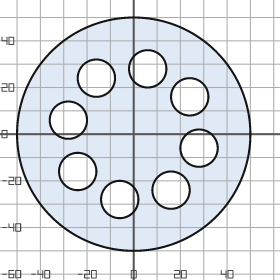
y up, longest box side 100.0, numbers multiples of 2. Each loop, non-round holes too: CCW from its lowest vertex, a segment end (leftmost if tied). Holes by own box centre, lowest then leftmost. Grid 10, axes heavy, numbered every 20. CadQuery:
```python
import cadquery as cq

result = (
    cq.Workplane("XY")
    .moveTo(0.0, 0.0)
    .circle(50.0)
    .moveTo(-6.0, -28.0)
    .circle(8.0)
    .moveTo(16.0, -24.0)
    .circle(8.0)
    .moveTo(-24.0, -16.0)
    .circle(8.0)
    .moveTo(28.0, -6.0)
    .circle(8.0)
    .moveTo(-28.0, 6.0)
    .circle(8.0)
    .moveTo(24.0, 16.0)
    .circle(8.0)
    .moveTo(-16.0, 24.0)
    .circle(8.0)
    .moveTo(6.0, 28.0)
    .circle(8.0)
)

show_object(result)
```